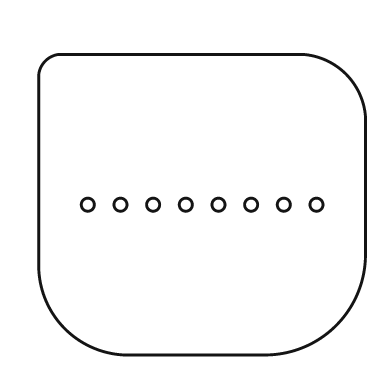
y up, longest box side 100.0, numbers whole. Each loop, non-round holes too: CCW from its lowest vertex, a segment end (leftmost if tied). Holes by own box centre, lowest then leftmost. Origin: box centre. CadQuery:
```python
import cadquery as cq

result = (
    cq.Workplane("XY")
    .moveTo(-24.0, -46.0)
    .lineTo(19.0, -46.0)
    .threePointArc((41.0, -37.0), (50.0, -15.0))
    .lineTo(50.0, 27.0)
    .threePointArc((44.0, 40.0), (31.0, 46.0))
    .lineTo(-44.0, 46.0)
    .threePointArc((-48.0, 44.0), (-50.0, 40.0))
    .lineTo(-50.0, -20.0)
    .threePointArc((-42.0, -38.0), (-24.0, -46.0))
    .close()
    .moveTo(-35.0, 0.0)
    .circle(2.0)
    .moveTo(-25.0, 0.0)
    .circle(2.0)
    .moveTo(-15.0, 0.0)
    .circle(2.0)
    .moveTo(-5.0, 0.0)
    .circle(2.0)
    .moveTo(5.0, 0.0)
    .circle(2.0)
    .moveTo(15.0, 0.0)
    .circle(2.0)
    .moveTo(25.0, 0.0)
    .circle(2.0)
    .moveTo(35.0, 0.0)
    .circle(2.0)
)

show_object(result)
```